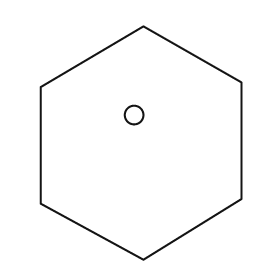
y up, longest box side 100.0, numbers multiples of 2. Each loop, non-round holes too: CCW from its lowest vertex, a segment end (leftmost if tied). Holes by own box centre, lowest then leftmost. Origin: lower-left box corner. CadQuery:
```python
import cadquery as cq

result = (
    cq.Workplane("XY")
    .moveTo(44.0, 0.0)
    .lineTo(86.0, 26.0)
    .lineTo(86.0, 76.0)
    .lineTo(44.0, 100.0)
    .lineTo(0.0, 74.0)
    .lineTo(0.0, 24.0)
    .close()
    .moveTo(40.0, 62.0)
    .circle(4.0)
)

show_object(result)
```